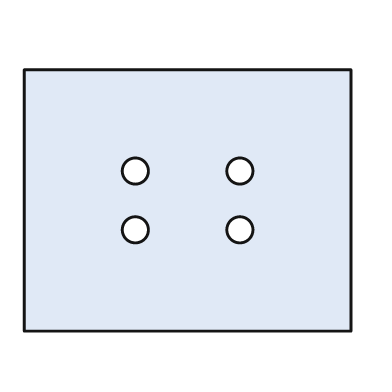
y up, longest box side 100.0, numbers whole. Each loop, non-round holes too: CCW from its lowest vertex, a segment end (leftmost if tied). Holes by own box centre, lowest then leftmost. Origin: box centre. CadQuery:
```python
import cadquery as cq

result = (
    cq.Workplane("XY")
    .moveTo(-50.0, -40.0)
    .lineTo(50.0, -40.0)
    .lineTo(50.0, 40.0)
    .lineTo(-50.0, 40.0)
    .close()
    .moveTo(-16.0, -9.0)
    .circle(4.0)
    .moveTo(16.0, -9.0)
    .circle(4.0)
    .moveTo(-16.0, 9.0)
    .circle(4.0)
    .moveTo(16.0, 9.0)
    .circle(4.0)
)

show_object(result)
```